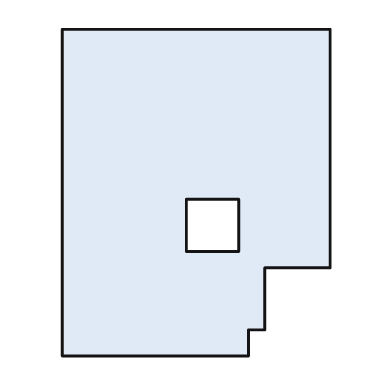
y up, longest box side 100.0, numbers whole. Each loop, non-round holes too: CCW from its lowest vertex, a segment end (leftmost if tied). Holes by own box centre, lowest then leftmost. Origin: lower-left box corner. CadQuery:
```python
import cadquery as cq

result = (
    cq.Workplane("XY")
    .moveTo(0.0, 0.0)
    .lineTo(57.0, 0.0)
    .lineTo(57.0, 8.0)
    .lineTo(62.0, 8.0)
    .lineTo(62.0, 27.0)
    .lineTo(82.0, 27.0)
    .lineTo(82.0, 100.0)
    .lineTo(0.0, 100.0)
    .close()
    .moveTo(38.0, 32.0)
    .lineTo(54.0, 32.0)
    .lineTo(54.0, 48.0)
    .lineTo(38.0, 48.0)
    .close()
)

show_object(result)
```